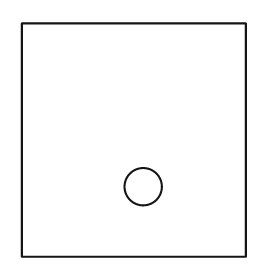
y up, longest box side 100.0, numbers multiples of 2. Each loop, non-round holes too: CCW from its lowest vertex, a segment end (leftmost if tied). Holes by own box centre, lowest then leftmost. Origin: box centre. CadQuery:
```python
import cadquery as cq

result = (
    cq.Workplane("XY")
    .moveTo(-48.0, -50.0)
    .lineTo(48.0, -50.0)
    .lineTo(48.0, 50.0)
    .lineTo(-48.0, 50.0)
    .close()
    .moveTo(4.0, -20.0)
    .circle(8.0)
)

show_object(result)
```